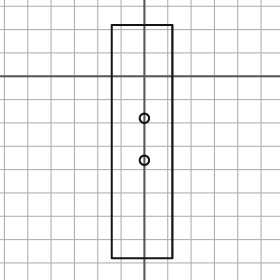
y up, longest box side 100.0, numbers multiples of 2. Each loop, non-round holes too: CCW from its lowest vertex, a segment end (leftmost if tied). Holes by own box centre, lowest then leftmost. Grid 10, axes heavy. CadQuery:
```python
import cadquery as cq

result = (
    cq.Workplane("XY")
    .moveTo(-14.0, -78.0)
    .lineTo(12.0, -78.0)
    .lineTo(12.0, 22.0)
    .lineTo(-14.0, 22.0)
    .close()
    .moveTo(0.0, -36.0)
    .circle(2.0)
    .moveTo(0.0, -18.0)
    .circle(2.0)
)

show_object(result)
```